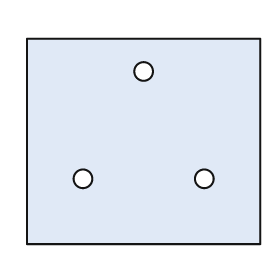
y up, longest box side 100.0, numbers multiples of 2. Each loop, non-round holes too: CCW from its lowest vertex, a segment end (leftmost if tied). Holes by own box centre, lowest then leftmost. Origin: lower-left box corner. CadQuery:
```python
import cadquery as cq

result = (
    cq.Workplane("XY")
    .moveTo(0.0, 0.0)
    .lineTo(100.0, 0.0)
    .lineTo(100.0, 88.0)
    .lineTo(0.0, 88.0)
    .close()
    .moveTo(24.0, 28.0)
    .circle(4.0)
    .moveTo(76.0, 28.0)
    .circle(4.0)
    .moveTo(50.0, 74.0)
    .circle(4.0)
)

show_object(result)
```